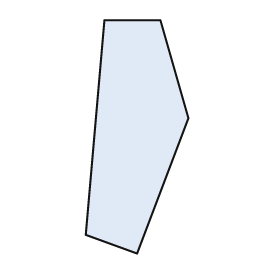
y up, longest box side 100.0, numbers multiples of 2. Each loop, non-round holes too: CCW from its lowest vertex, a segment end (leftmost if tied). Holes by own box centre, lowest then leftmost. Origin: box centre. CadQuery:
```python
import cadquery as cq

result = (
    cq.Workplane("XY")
    .moveTo(0.0, -50.0)
    .lineTo(22.0, 8.0)
    .lineTo(10.0, 50.0)
    .lineTo(-14.0, 50.0)
    .lineTo(-22.0, -42.0)
    .close()
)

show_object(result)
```